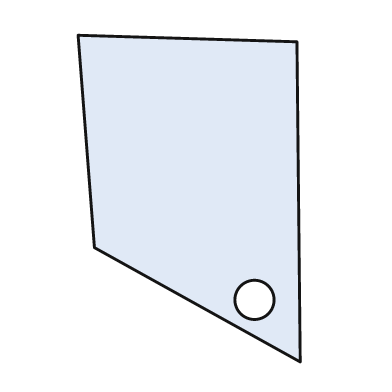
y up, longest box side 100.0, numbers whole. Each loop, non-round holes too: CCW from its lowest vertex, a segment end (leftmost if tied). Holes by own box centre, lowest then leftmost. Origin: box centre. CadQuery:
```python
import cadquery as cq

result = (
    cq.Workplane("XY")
    .moveTo(34.0, -50.0)
    .lineTo(33.0, 48.0)
    .lineTo(-34.0, 50.0)
    .lineTo(-29.0, -15.0)
    .close()
    .moveTo(20.0, -31.0)
    .circle(6.0)
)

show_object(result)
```